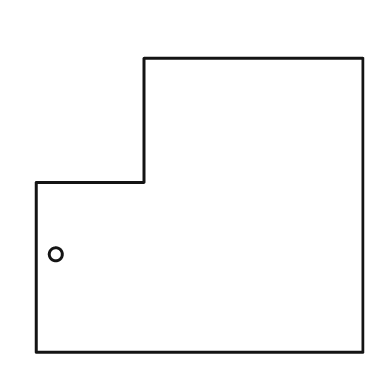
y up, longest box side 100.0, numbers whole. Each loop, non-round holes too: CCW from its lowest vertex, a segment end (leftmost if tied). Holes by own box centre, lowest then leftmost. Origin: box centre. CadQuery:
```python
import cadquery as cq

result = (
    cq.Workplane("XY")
    .moveTo(-50.0, -45.0)
    .lineTo(50.0, -45.0)
    .lineTo(50.0, 45.0)
    .lineTo(-17.0, 45.0)
    .lineTo(-17.0, 7.0)
    .lineTo(-50.0, 7.0)
    .close()
    .moveTo(-44.0, -15.0)
    .circle(2.0)
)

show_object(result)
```